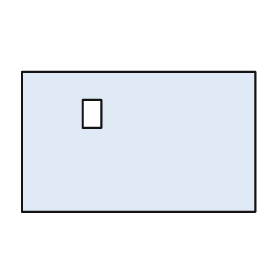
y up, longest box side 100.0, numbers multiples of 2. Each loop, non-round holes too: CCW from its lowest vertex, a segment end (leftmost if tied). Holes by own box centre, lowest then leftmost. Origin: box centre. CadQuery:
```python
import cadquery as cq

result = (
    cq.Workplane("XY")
    .moveTo(-50.0, -30.0)
    .lineTo(50.0, -30.0)
    .lineTo(50.0, 30.0)
    .lineTo(-50.0, 30.0)
    .close()
    .moveTo(-24.0, 6.0)
    .lineTo(-16.0, 6.0)
    .lineTo(-16.0, 18.0)
    .lineTo(-24.0, 18.0)
    .close()
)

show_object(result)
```